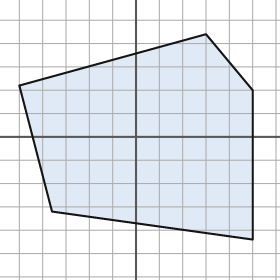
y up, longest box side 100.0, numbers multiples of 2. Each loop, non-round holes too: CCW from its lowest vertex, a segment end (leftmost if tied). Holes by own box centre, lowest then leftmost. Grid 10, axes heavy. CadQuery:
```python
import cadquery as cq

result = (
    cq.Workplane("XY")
    .moveTo(50.0, -44.0)
    .lineTo(50.0, 20.0)
    .lineTo(30.0, 44.0)
    .lineTo(-50.0, 22.0)
    .lineTo(-36.0, -32.0)
    .close()
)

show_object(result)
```